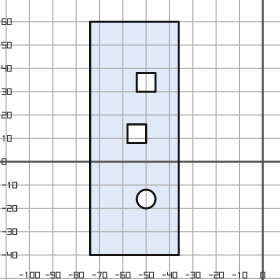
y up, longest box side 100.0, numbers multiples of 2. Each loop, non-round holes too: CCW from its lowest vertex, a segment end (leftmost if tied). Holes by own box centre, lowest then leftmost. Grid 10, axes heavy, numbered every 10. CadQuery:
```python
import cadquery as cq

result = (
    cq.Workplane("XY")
    .moveTo(-74.0, -40.0)
    .lineTo(-36.0, -40.0)
    .lineTo(-36.0, 60.0)
    .lineTo(-74.0, 60.0)
    .close()
    .moveTo(-50.0, -16.0)
    .circle(4.0)
    .moveTo(-58.0, 8.0)
    .lineTo(-50.0, 8.0)
    .lineTo(-50.0, 16.0)
    .lineTo(-58.0, 16.0)
    .close()
    .moveTo(-54.0, 30.0)
    .lineTo(-46.0, 30.0)
    .lineTo(-46.0, 38.0)
    .lineTo(-54.0, 38.0)
    .close()
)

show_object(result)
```